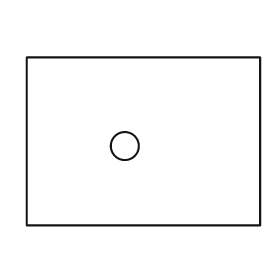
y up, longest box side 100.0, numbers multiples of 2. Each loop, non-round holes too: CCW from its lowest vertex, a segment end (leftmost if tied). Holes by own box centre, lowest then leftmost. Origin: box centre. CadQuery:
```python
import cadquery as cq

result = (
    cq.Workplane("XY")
    .moveTo(-50.0, -36.0)
    .lineTo(50.0, -36.0)
    .lineTo(50.0, 36.0)
    .lineTo(-50.0, 36.0)
    .close()
    .moveTo(-8.0, -2.0)
    .circle(6.0)
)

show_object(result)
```